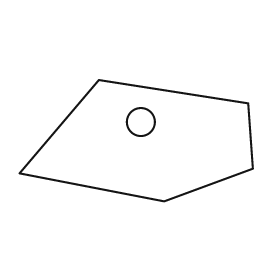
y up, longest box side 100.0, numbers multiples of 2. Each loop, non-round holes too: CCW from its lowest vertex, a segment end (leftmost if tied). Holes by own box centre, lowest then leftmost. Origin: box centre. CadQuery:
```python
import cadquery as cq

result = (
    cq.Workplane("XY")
    .moveTo(12.0, -26.0)
    .lineTo(50.0, -12.0)
    .lineTo(48.0, 16.0)
    .lineTo(-16.0, 26.0)
    .lineTo(-50.0, -14.0)
    .close()
    .moveTo(2.0, 8.0)
    .circle(6.0)
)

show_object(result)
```